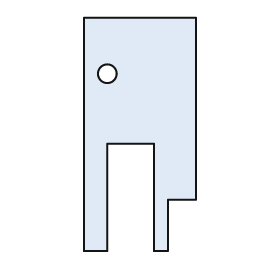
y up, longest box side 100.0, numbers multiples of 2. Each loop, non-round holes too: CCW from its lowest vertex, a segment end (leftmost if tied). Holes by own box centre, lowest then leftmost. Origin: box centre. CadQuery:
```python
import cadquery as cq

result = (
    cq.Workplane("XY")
    .moveTo(-24.0, -50.0)
    .lineTo(-14.0, -50.0)
    .lineTo(-14.0, -4.0)
    .lineTo(6.0, -4.0)
    .lineTo(6.0, -50.0)
    .lineTo(12.0, -50.0)
    .lineTo(12.0, -28.0)
    .lineTo(24.0, -28.0)
    .lineTo(24.0, 50.0)
    .lineTo(-24.0, 50.0)
    .close()
    .moveTo(-14.0, 26.0)
    .circle(4.0)
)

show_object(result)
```